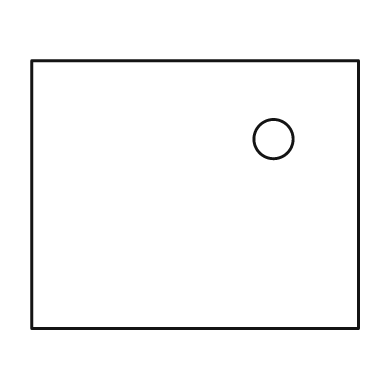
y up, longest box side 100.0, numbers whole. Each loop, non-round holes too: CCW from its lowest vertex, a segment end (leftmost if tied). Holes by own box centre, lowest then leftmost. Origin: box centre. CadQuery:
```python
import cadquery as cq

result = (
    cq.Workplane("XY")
    .moveTo(-50.0, -41.0)
    .lineTo(50.0, -41.0)
    .lineTo(50.0, 41.0)
    .lineTo(-50.0, 41.0)
    .close()
    .moveTo(24.0, 17.0)
    .circle(6.0)
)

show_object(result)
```